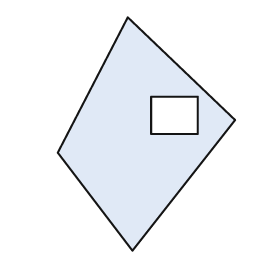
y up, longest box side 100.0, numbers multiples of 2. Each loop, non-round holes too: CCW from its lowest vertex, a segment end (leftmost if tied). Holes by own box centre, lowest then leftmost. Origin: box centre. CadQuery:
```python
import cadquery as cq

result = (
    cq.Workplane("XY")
    .moveTo(-6.0, -50.0)
    .lineTo(38.0, 6.0)
    .lineTo(-8.0, 50.0)
    .lineTo(-38.0, -8.0)
    .close()
    .moveTo(2.0, 0.0)
    .lineTo(22.0, 0.0)
    .lineTo(22.0, 16.0)
    .lineTo(2.0, 16.0)
    .close()
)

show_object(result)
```